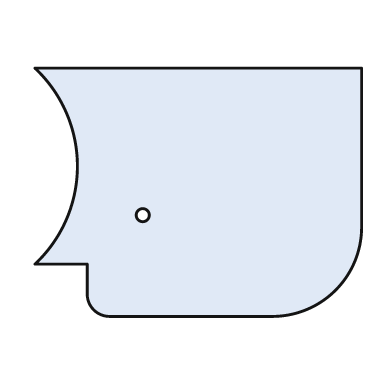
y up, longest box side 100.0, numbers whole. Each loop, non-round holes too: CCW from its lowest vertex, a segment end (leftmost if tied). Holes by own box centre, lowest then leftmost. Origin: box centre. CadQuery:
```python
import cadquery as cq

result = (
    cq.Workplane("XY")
    .moveTo(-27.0, -38.0)
    .lineTo(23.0, -38.0)
    .threePointArc((42.0, -30.0), (50.0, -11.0))
    .lineTo(50.0, 38.0)
    .lineTo(-50.0, 38.0)
    .threePointArc((-37.0, 8.0), (-50.0, -22.0))
    .lineTo(-34.0, -22.0)
    .lineTo(-34.0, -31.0)
    .threePointArc((-32.0, -36.0), (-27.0, -38.0))
    .close()
    .moveTo(-17.0, -7.0)
    .circle(2.0)
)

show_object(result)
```